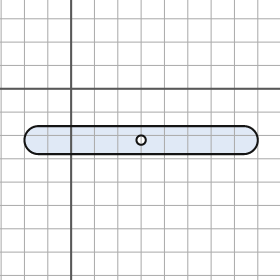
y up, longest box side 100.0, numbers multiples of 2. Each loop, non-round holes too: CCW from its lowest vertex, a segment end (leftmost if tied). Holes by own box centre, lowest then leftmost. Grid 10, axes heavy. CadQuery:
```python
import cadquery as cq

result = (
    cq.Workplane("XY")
    .moveTo(-14.0, -28.0)
    .lineTo(74.0, -28.0)
    .threePointArc((80.0, -22.0), (74.0, -16.0))
    .lineTo(-14.0, -16.0)
    .threePointArc((-20.0, -22.0), (-14.0, -28.0))
    .close()
    .moveTo(30.0, -22.0)
    .circle(2.0)
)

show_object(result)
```